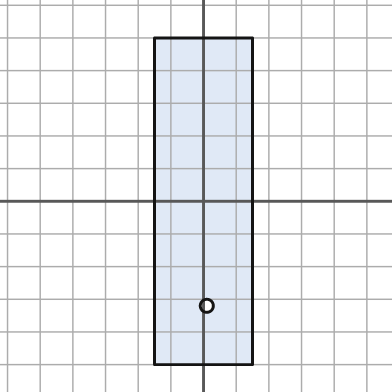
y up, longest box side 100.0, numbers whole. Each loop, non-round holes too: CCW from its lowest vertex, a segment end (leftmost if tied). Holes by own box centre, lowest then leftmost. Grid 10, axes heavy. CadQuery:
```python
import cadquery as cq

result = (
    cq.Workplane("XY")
    .moveTo(-15.0, -50.0)
    .lineTo(15.0, -50.0)
    .lineTo(15.0, 50.0)
    .lineTo(-15.0, 50.0)
    .close()
    .moveTo(1.0, -32.0)
    .circle(2.0)
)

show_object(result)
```